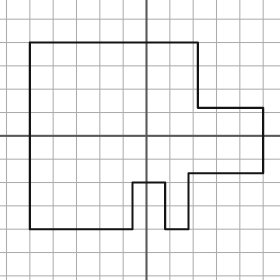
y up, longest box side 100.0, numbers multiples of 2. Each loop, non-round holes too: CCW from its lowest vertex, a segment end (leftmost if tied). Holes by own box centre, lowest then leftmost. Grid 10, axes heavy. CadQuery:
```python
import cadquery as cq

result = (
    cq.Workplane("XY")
    .moveTo(-50.0, -40.0)
    .lineTo(-6.0, -40.0)
    .lineTo(-6.0, -20.0)
    .lineTo(8.0, -20.0)
    .lineTo(8.0, -40.0)
    .lineTo(18.0, -40.0)
    .lineTo(18.0, -16.0)
    .lineTo(50.0, -16.0)
    .lineTo(50.0, 12.0)
    .lineTo(22.0, 12.0)
    .lineTo(22.0, 40.0)
    .lineTo(-50.0, 40.0)
    .close()
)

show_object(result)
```